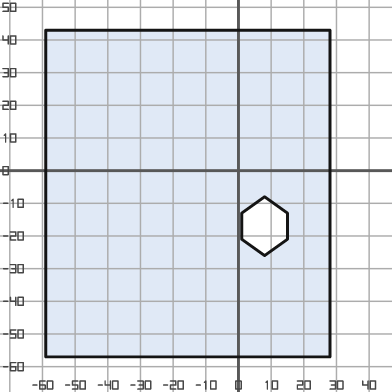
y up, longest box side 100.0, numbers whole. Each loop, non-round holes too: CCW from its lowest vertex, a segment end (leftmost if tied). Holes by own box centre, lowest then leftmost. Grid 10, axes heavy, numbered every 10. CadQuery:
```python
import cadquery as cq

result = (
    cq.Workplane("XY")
    .moveTo(-59.0, -57.0)
    .lineTo(28.0, -57.0)
    .lineTo(28.0, 43.0)
    .lineTo(-59.0, 43.0)
    .close()
    .moveTo(8.0, -26.0)
    .lineTo(15.0, -21.0)
    .lineTo(15.0, -13.0)
    .lineTo(8.0, -8.0)
    .lineTo(1.0, -13.0)
    .lineTo(1.0, -21.0)
    .close()
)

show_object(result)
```